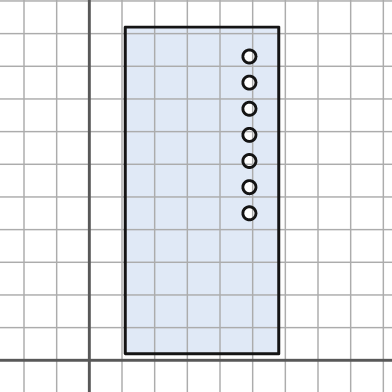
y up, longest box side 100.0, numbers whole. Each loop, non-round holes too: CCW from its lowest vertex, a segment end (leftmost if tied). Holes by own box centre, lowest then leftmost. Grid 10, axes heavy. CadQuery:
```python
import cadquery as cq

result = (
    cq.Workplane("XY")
    .moveTo(11.0, 2.0)
    .lineTo(58.0, 2.0)
    .lineTo(58.0, 102.0)
    .lineTo(11.0, 102.0)
    .close()
    .moveTo(49.0, 45.0)
    .circle(2.0)
    .moveTo(49.0, 53.0)
    .circle(2.0)
    .moveTo(49.0, 61.0)
    .circle(2.0)
    .moveTo(49.0, 69.0)
    .circle(2.0)
    .moveTo(49.0, 77.0)
    .circle(2.0)
    .moveTo(49.0, 85.0)
    .circle(2.0)
    .moveTo(49.0, 93.0)
    .circle(2.0)
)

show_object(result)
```